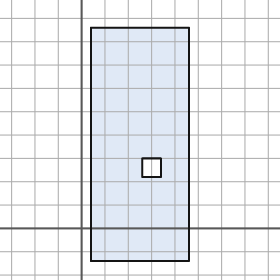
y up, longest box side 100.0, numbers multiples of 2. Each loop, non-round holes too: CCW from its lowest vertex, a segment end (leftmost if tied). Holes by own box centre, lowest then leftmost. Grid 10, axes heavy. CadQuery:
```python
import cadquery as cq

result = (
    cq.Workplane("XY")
    .moveTo(4.0, -14.0)
    .lineTo(46.0, -14.0)
    .lineTo(46.0, 86.0)
    .lineTo(4.0, 86.0)
    .close()
    .moveTo(26.0, 22.0)
    .lineTo(34.0, 22.0)
    .lineTo(34.0, 30.0)
    .lineTo(26.0, 30.0)
    .close()
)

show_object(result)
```